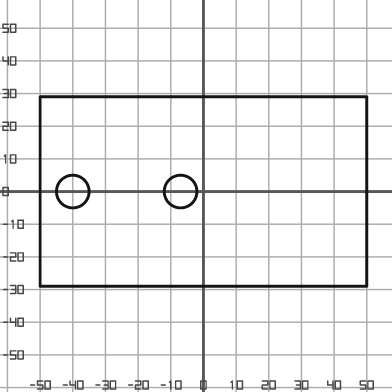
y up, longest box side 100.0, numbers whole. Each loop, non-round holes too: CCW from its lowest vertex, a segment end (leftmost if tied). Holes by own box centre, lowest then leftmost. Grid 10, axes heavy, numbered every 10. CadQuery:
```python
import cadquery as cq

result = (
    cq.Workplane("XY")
    .moveTo(-50.0, -29.0)
    .lineTo(50.0, -29.0)
    .lineTo(50.0, 29.0)
    .lineTo(-50.0, 29.0)
    .close()
    .moveTo(-40.0, 0.0)
    .circle(5.0)
    .moveTo(-7.0, 0.0)
    .circle(5.0)
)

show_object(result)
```